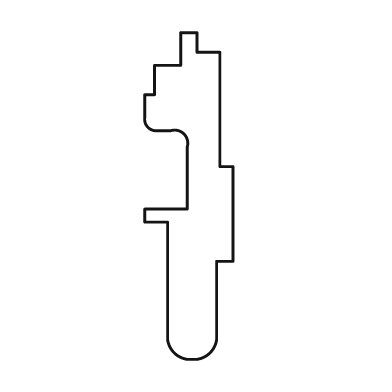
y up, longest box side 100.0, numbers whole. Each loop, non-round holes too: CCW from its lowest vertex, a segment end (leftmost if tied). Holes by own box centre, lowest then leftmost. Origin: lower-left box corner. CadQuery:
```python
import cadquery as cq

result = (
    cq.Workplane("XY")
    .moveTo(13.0, 0.0)
    .lineTo(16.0, 0.0)
    .threePointArc((20.0, 2.0), (22.0, 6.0))
    .lineTo(22.0, 30.0)
    .lineTo(27.0, 30.0)
    .lineTo(27.0, 59.0)
    .lineTo(23.0, 59.0)
    .lineTo(23.0, 94.0)
    .lineTo(16.0, 94.0)
    .lineTo(16.0, 100.0)
    .lineTo(11.0, 100.0)
    .lineTo(11.0, 90.0)
    .lineTo(3.0, 90.0)
    .lineTo(3.0, 81.0)
    .lineTo(0.0, 81.0)
    .lineTo(0.0, 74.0)
    .threePointArc((1.0, 71.0), (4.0, 70.0))
    .lineTo(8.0, 70.0)
    .threePointArc((12.0, 69.0), (13.0, 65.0))
    .lineTo(13.0, 46.0)
    .lineTo(0.0, 46.0)
    .lineTo(0.0, 42.0)
    .lineTo(7.0, 42.0)
    .lineTo(7.0, 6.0)
    .threePointArc((9.0, 2.0), (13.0, 0.0))
    .close()
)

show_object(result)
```